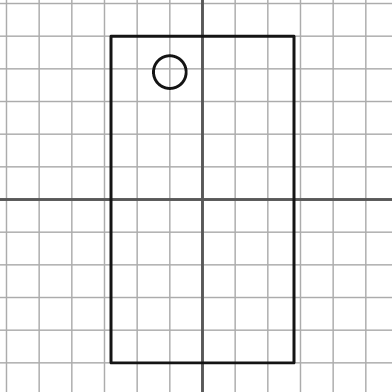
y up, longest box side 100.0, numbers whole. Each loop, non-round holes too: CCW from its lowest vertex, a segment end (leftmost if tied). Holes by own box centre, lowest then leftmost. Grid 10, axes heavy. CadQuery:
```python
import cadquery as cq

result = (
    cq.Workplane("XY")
    .moveTo(-28.0, -50.0)
    .lineTo(28.0, -50.0)
    .lineTo(28.0, 50.0)
    .lineTo(-28.0, 50.0)
    .close()
    .moveTo(-10.0, 39.0)
    .circle(5.0)
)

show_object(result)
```